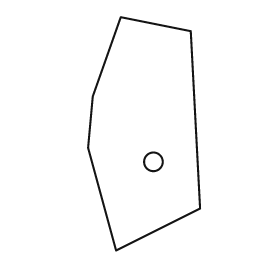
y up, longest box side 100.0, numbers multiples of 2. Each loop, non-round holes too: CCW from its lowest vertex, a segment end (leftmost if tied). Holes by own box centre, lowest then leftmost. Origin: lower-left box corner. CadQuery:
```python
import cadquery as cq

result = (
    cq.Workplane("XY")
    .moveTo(12.0, 0.0)
    .lineTo(48.0, 18.0)
    .lineTo(44.0, 94.0)
    .lineTo(14.0, 100.0)
    .lineTo(2.0, 66.0)
    .lineTo(0.0, 44.0)
    .close()
    .moveTo(28.0, 38.0)
    .circle(4.0)
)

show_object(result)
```